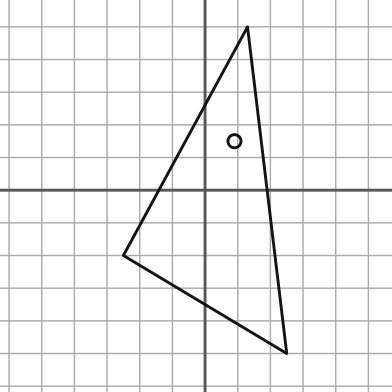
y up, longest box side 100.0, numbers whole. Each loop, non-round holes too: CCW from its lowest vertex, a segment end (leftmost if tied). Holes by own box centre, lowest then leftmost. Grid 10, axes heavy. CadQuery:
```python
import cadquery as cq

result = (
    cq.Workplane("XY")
    .moveTo(25.0, -50.0)
    .lineTo(13.0, 50.0)
    .lineTo(-25.0, -20.0)
    .close()
    .moveTo(9.0, 15.0)
    .circle(2.0)
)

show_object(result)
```